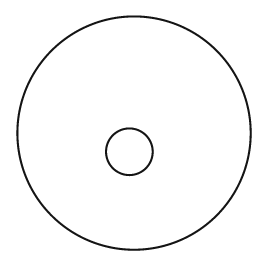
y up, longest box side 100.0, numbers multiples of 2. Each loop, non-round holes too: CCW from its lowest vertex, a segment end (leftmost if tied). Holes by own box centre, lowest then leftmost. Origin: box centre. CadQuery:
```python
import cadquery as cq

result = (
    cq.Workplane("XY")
    .moveTo(0.0, 0.0)
    .circle(50.0)
    .moveTo(-2.0, -8.0)
    .circle(10.0)
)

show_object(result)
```